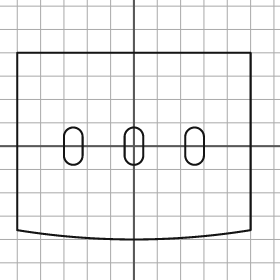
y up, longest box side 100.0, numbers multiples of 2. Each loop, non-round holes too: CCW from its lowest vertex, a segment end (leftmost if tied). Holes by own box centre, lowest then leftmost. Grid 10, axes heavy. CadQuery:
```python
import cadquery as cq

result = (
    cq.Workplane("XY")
    .moveTo(-50.0, -36.0)
    .threePointArc((0.0, -40.0), (50.0, -36.0))
    .lineTo(50.0, 40.0)
    .lineTo(-50.0, 40.0)
    .close()
    .moveTo(-30.0, -4.0)
    .threePointArc((-26.0, -8.0), (-22.0, -4.0))
    .lineTo(-22.0, 4.0)
    .threePointArc((-26.0, 8.0), (-30.0, 4.0))
    .close()
    .moveTo(-4.0, -4.0)
    .threePointArc((0.0, -8.0), (4.0, -4.0))
    .lineTo(4.0, 4.0)
    .threePointArc((0.0, 8.0), (-4.0, 4.0))
    .close()
    .moveTo(22.0, -4.0)
    .threePointArc((26.0, -8.0), (30.0, -4.0))
    .lineTo(30.0, 4.0)
    .threePointArc((26.0, 8.0), (22.0, 4.0))
    .close()
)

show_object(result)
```